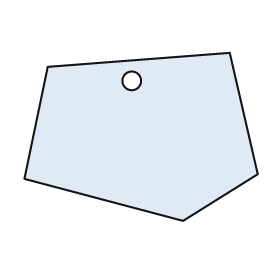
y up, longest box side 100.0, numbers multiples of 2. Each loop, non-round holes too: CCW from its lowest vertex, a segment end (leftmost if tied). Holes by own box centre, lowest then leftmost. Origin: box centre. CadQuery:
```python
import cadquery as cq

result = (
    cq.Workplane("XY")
    .moveTo(18.0, -36.0)
    .lineTo(50.0, -16.0)
    .lineTo(38.0, 36.0)
    .lineTo(-40.0, 30.0)
    .lineTo(-50.0, -18.0)
    .close()
    .moveTo(-4.0, 24.0)
    .circle(4.0)
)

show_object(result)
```